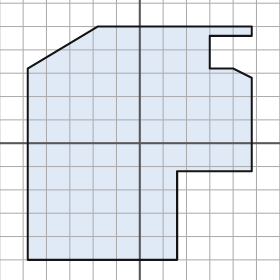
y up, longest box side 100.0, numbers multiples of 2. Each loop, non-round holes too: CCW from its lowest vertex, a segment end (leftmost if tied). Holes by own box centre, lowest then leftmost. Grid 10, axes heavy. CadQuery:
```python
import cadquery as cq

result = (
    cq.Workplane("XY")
    .moveTo(-48.0, -50.0)
    .lineTo(16.0, -50.0)
    .lineTo(16.0, -12.0)
    .lineTo(48.0, -12.0)
    .lineTo(48.0, 28.0)
    .lineTo(40.0, 32.0)
    .lineTo(30.0, 32.0)
    .lineTo(30.0, 46.0)
    .lineTo(48.0, 46.0)
    .lineTo(48.0, 50.0)
    .lineTo(-18.0, 50.0)
    .lineTo(-48.0, 32.0)
    .close()
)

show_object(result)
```